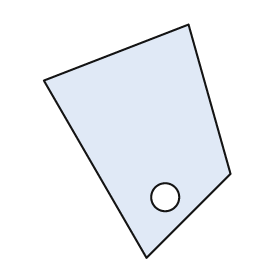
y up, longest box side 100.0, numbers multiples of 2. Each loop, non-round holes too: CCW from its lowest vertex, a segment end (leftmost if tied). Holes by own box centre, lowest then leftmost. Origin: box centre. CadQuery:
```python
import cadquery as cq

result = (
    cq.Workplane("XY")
    .moveTo(4.0, -50.0)
    .lineTo(40.0, -14.0)
    .lineTo(22.0, 50.0)
    .lineTo(-40.0, 26.0)
    .close()
    .moveTo(12.0, -24.0)
    .circle(6.0)
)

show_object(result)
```